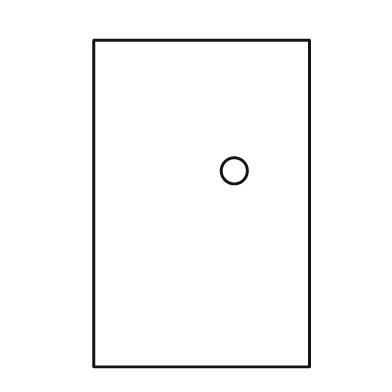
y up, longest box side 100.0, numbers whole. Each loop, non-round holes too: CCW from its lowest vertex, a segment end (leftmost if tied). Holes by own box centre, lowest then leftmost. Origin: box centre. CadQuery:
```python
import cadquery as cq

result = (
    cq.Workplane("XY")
    .moveTo(-33.0, -50.0)
    .lineTo(33.0, -50.0)
    .lineTo(33.0, 50.0)
    .lineTo(-33.0, 50.0)
    .close()
    .moveTo(10.0, 10.0)
    .circle(4.0)
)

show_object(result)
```